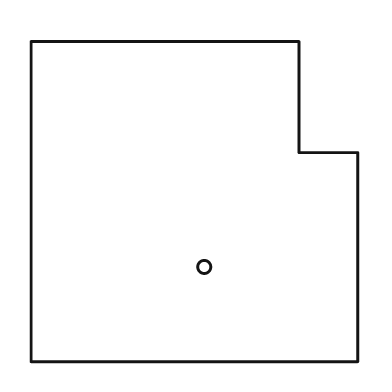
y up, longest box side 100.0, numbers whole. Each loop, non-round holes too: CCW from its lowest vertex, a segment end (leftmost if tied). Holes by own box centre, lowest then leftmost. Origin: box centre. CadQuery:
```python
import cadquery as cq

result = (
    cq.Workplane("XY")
    .moveTo(-50.0, -49.0)
    .lineTo(50.0, -49.0)
    .lineTo(50.0, 15.0)
    .lineTo(32.0, 15.0)
    .lineTo(32.0, 49.0)
    .lineTo(-50.0, 49.0)
    .close()
    .moveTo(3.0, -20.0)
    .circle(2.0)
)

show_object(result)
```